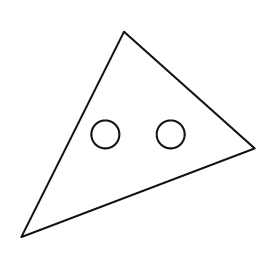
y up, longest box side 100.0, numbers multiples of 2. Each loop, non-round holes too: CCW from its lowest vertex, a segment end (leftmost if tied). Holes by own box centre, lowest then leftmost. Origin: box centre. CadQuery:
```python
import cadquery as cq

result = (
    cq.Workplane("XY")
    .moveTo(-50.0, -44.0)
    .lineTo(50.0, -6.0)
    .lineTo(-6.0, 44.0)
    .close()
    .moveTo(-14.0, 0.0)
    .circle(6.0)
    .moveTo(14.0, 0.0)
    .circle(6.0)
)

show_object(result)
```